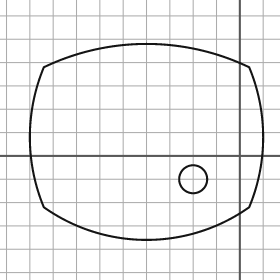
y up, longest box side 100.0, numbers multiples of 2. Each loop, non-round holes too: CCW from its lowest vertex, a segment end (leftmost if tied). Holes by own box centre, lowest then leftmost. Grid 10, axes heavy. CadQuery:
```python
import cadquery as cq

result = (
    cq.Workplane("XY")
    .moveTo(-84.0, -22.0)
    .threePointArc((-40.0, -36.0), (4.0, -22.0))
    .threePointArc((10.0, 8.0), (4.0, 38.0))
    .threePointArc((-40.0, 48.0), (-84.0, 38.0))
    .threePointArc((-90.0, 8.0), (-84.0, -22.0))
    .close()
    .moveTo(-20.0, -10.0)
    .circle(6.0)
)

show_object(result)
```